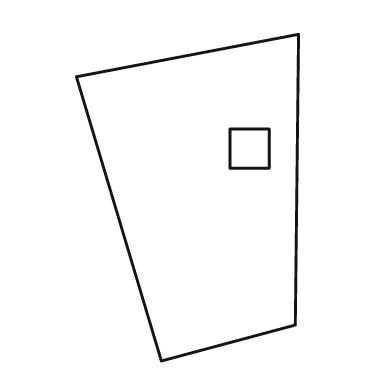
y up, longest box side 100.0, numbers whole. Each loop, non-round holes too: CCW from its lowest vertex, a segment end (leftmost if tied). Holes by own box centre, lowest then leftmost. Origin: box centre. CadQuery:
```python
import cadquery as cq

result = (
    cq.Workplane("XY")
    .moveTo(-8.0, -50.0)
    .lineTo(33.0, -39.0)
    .lineTo(34.0, 50.0)
    .lineTo(-34.0, 37.0)
    .close()
    .moveTo(13.0, 9.0)
    .lineTo(25.0, 9.0)
    .lineTo(25.0, 21.0)
    .lineTo(13.0, 21.0)
    .close()
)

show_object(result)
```